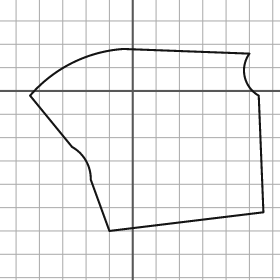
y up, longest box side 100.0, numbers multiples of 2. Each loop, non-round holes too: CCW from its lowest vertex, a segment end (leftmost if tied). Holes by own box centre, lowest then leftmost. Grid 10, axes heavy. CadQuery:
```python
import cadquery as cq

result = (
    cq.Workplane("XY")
    .moveTo(-10.0, -60.0)
    .lineTo(56.0, -52.0)
    .lineTo(54.0, -2.0)
    .threePointArc((48.0, 6.0), (50.0, 16.0))
    .lineTo(-4.0, 18.0)
    .threePointArc((-26.0, 12.0), (-44.0, -2.0))
    .lineTo(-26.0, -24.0)
    .threePointArc((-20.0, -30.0), (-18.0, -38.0))
    .close()
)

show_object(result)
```